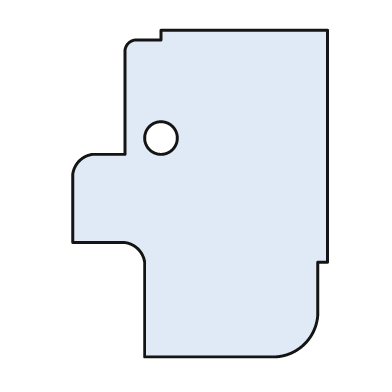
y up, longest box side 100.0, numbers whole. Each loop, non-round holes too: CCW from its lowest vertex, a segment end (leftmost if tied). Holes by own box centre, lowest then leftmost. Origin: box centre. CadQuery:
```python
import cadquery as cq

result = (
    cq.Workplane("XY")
    .moveTo(-17.0, -50.0)
    .lineTo(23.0, -50.0)
    .threePointArc((32.0, -46.0), (36.0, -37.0))
    .lineTo(36.0, -21.0)
    .lineTo(39.0, -21.0)
    .lineTo(39.0, 50.0)
    .lineTo(-12.0, 50.0)
    .lineTo(-12.0, 47.0)
    .lineTo(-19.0, 47.0)
    .threePointArc((-22.0, 46.0), (-23.0, 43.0))
    .lineTo(-23.0, 12.0)
    .lineTo(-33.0, 12.0)
    .threePointArc((-37.0, 10.0), (-39.0, 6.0))
    .lineTo(-39.0, -15.0)
    .lineTo(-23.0, -15.0)
    .threePointArc((-19.0, -17.0), (-17.0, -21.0))
    .close()
    .moveTo(-12.0, 17.0)
    .circle(5.0)
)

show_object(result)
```